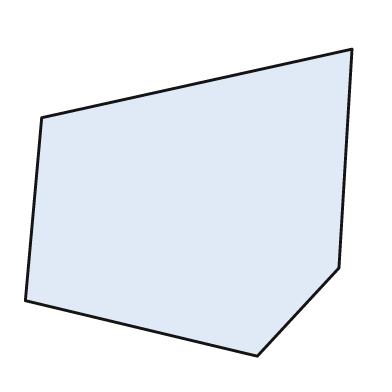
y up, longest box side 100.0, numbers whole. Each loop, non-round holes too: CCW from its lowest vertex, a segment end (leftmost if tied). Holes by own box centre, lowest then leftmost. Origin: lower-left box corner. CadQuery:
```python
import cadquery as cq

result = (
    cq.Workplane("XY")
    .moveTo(71.0, 0.0)
    .lineTo(96.0, 27.0)
    .lineTo(100.0, 94.0)
    .lineTo(5.0, 73.0)
    .lineTo(0.0, 17.0)
    .close()
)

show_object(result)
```